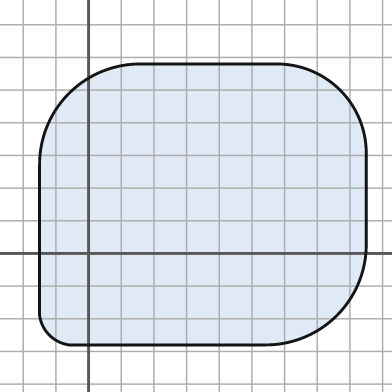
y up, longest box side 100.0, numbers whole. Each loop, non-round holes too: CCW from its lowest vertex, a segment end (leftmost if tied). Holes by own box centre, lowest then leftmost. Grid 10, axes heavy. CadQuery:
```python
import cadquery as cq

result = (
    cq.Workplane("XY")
    .moveTo(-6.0, -28.0)
    .lineTo(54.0, -28.0)
    .threePointArc((76.0, -19.0), (85.0, 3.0))
    .lineTo(85.0, 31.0)
    .threePointArc((77.0, 50.0), (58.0, 58.0))
    .lineTo(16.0, 58.0)
    .threePointArc((-6.0, 49.0), (-15.0, 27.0))
    .lineTo(-15.0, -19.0)
    .threePointArc((-12.0, -25.0), (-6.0, -28.0))
    .close()
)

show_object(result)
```